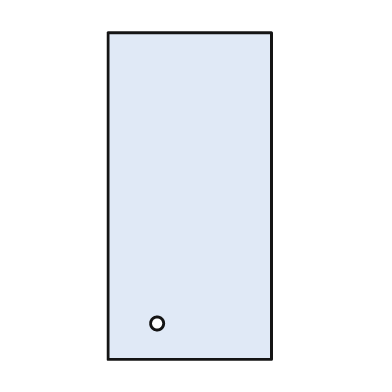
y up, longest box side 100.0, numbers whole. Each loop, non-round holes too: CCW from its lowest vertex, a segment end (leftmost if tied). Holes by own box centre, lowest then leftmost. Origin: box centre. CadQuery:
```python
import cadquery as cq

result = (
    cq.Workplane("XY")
    .moveTo(-25.0, -50.0)
    .lineTo(25.0, -50.0)
    .lineTo(25.0, 50.0)
    .lineTo(-25.0, 50.0)
    .close()
    .moveTo(-10.0, -39.0)
    .circle(2.0)
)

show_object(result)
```